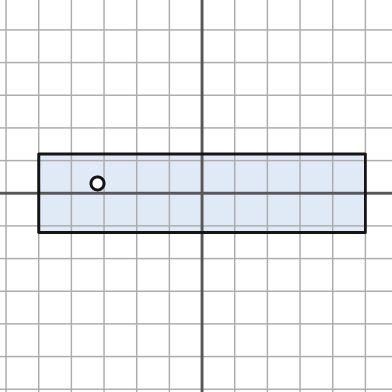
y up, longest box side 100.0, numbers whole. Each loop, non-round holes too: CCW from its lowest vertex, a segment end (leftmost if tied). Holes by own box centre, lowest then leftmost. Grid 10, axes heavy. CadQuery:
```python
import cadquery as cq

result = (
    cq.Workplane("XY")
    .moveTo(-50.0, -12.0)
    .lineTo(50.0, -12.0)
    .lineTo(50.0, 12.0)
    .lineTo(-50.0, 12.0)
    .close()
    .moveTo(-32.0, 3.0)
    .circle(2.0)
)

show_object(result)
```